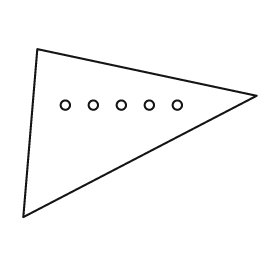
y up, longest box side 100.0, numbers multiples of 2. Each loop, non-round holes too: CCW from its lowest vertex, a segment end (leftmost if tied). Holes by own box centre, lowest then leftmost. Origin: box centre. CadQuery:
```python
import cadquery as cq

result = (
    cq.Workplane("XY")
    .moveTo(-50.0, -36.0)
    .lineTo(50.0, 16.0)
    .lineTo(-44.0, 36.0)
    .close()
    .moveTo(-32.0, 12.0)
    .circle(2.0)
    .moveTo(-20.0, 12.0)
    .circle(2.0)
    .moveTo(-8.0, 12.0)
    .circle(2.0)
    .moveTo(4.0, 12.0)
    .circle(2.0)
    .moveTo(16.0, 12.0)
    .circle(2.0)
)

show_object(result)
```